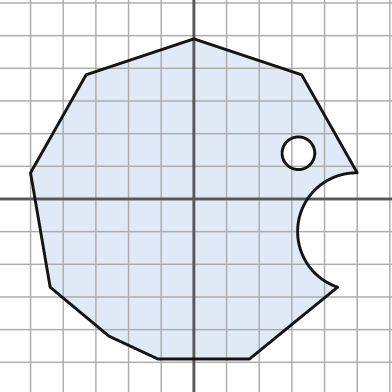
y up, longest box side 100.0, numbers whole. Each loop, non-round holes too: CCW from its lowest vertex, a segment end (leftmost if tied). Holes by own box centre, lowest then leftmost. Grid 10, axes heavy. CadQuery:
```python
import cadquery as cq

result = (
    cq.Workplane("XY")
    .moveTo(-11.0, -49.0)
    .lineTo(17.0, -49.0)
    .lineTo(44.0, -27.0)
    .threePointArc((32.0, -7.0), (50.0, 8.0))
    .lineTo(33.0, 38.0)
    .lineTo(0.0, 49.0)
    .lineTo(-33.0, 38.0)
    .lineTo(-50.0, 8.0)
    .lineTo(-44.0, -27.0)
    .lineTo(-26.0, -42.0)
    .close()
    .moveTo(32.0, 14.0)
    .circle(5.0)
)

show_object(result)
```